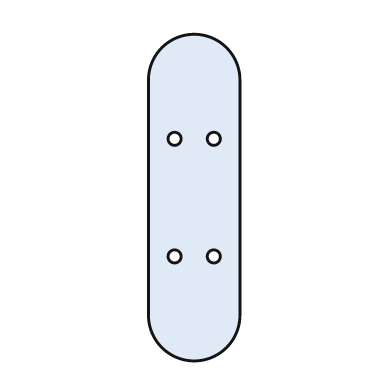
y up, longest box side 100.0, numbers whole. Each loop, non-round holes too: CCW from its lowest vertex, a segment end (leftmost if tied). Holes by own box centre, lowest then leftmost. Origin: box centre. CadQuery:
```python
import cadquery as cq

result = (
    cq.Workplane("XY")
    .moveTo(-14.0, -36.0)
    .threePointArc((0.0, -50.0), (14.0, -36.0))
    .lineTo(14.0, 36.0)
    .threePointArc((0.0, 50.0), (-14.0, 36.0))
    .close()
    .moveTo(-6.0, -18.0)
    .circle(2.0)
    .moveTo(6.0, -18.0)
    .circle(2.0)
    .moveTo(-6.0, 18.0)
    .circle(2.0)
    .moveTo(6.0, 18.0)
    .circle(2.0)
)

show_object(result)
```